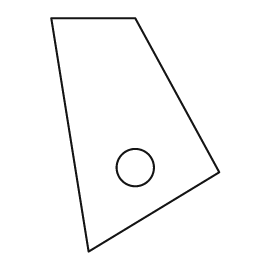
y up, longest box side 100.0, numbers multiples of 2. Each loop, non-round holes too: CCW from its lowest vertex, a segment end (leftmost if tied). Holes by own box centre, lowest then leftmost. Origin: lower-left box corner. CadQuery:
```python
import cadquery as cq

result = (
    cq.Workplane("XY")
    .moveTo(16.0, 0.0)
    .lineTo(72.0, 34.0)
    .lineTo(36.0, 100.0)
    .lineTo(0.0, 100.0)
    .close()
    .moveTo(36.0, 36.0)
    .circle(8.0)
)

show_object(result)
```